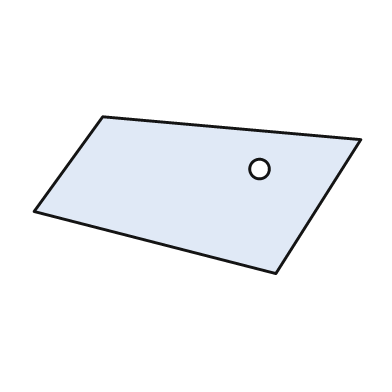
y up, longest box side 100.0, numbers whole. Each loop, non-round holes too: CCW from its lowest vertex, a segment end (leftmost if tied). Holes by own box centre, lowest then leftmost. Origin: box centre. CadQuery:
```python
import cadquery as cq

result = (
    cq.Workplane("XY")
    .moveTo(24.0, -24.0)
    .lineTo(50.0, 17.0)
    .lineTo(-29.0, 24.0)
    .lineTo(-50.0, -5.0)
    .close()
    .moveTo(19.0, 8.0)
    .circle(3.0)
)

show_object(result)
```